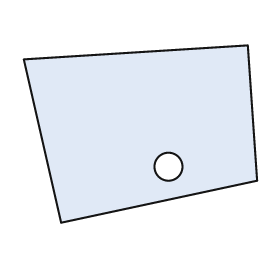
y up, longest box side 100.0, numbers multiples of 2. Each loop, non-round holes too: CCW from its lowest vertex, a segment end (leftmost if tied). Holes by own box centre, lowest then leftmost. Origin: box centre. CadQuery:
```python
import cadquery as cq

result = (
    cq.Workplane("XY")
    .moveTo(-34.0, -38.0)
    .lineTo(50.0, -20.0)
    .lineTo(46.0, 38.0)
    .lineTo(-50.0, 32.0)
    .close()
    .moveTo(12.0, -14.0)
    .circle(6.0)
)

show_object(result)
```